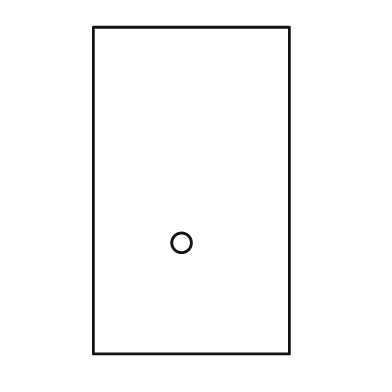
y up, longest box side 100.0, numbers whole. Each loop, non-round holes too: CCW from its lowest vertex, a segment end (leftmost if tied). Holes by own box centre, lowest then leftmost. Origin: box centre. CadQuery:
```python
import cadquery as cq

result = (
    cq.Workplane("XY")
    .moveTo(-30.0, -50.0)
    .lineTo(30.0, -50.0)
    .lineTo(30.0, 50.0)
    .lineTo(-30.0, 50.0)
    .close()
    .moveTo(-3.0, -16.0)
    .circle(3.0)
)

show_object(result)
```